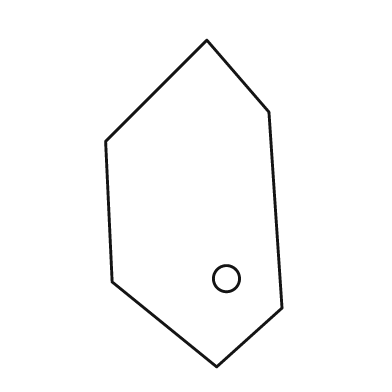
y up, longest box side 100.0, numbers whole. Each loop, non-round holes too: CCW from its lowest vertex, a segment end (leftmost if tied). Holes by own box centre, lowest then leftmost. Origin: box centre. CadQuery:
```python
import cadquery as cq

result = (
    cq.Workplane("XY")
    .moveTo(7.0, -50.0)
    .lineTo(27.0, -32.0)
    .lineTo(23.0, 28.0)
    .lineTo(4.0, 50.0)
    .lineTo(-27.0, 19.0)
    .lineTo(-25.0, -24.0)
    .close()
    .moveTo(10.0, -23.0)
    .circle(4.0)
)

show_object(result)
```